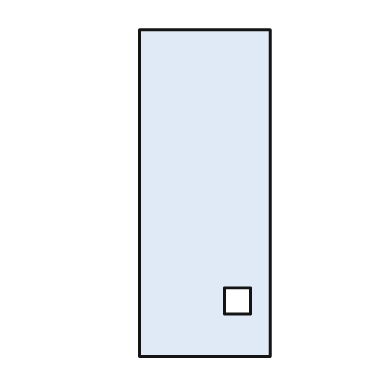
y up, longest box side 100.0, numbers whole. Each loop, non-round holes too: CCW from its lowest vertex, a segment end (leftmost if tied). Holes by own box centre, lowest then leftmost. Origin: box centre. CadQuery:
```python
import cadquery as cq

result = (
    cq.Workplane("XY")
    .moveTo(-20.0, -50.0)
    .lineTo(20.0, -50.0)
    .lineTo(20.0, 50.0)
    .lineTo(-20.0, 50.0)
    .close()
    .moveTo(6.0, -37.0)
    .lineTo(14.0, -37.0)
    .lineTo(14.0, -29.0)
    .lineTo(6.0, -29.0)
    .close()
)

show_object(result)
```